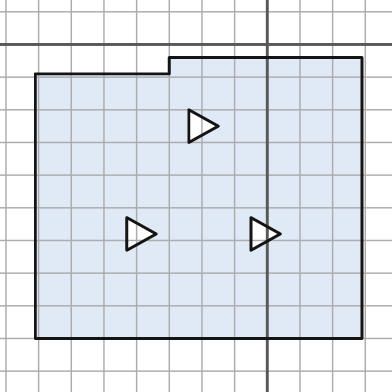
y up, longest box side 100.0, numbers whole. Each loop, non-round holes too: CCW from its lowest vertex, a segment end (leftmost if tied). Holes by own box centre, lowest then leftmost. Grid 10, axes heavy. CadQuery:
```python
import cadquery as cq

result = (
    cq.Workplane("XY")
    .moveTo(-71.0, -90.0)
    .lineTo(29.0, -90.0)
    .lineTo(29.0, -4.0)
    .lineTo(-30.0, -4.0)
    .lineTo(-30.0, -9.0)
    .lineTo(-71.0, -9.0)
    .close()
    .moveTo(-43.0, -63.0)
    .lineTo(-34.0, -58.0)
    .lineTo(-43.0, -53.0)
    .close()
    .moveTo(-5.0, -63.0)
    .lineTo(4.0, -58.0)
    .lineTo(-5.0, -53.0)
    .close()
    .moveTo(-24.0, -30.0)
    .lineTo(-15.0, -25.0)
    .lineTo(-24.0, -20.0)
    .close()
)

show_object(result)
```